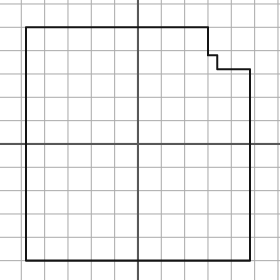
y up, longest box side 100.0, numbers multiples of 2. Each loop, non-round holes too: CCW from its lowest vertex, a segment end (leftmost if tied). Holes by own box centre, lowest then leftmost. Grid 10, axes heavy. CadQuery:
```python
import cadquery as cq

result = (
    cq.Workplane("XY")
    .moveTo(-48.0, -50.0)
    .lineTo(48.0, -50.0)
    .lineTo(48.0, 32.0)
    .lineTo(34.0, 32.0)
    .lineTo(34.0, 38.0)
    .lineTo(30.0, 38.0)
    .lineTo(30.0, 50.0)
    .lineTo(-48.0, 50.0)
    .close()
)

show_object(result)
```